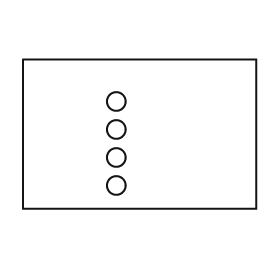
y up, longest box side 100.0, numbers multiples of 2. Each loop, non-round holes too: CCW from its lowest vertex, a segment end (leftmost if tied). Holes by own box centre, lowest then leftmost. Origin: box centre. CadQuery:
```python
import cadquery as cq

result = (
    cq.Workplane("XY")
    .moveTo(-50.0, -32.0)
    .lineTo(50.0, -32.0)
    .lineTo(50.0, 32.0)
    .lineTo(-50.0, 32.0)
    .close()
    .moveTo(-10.0, -22.0)
    .circle(4.0)
    .moveTo(-10.0, -10.0)
    .circle(4.0)
    .moveTo(-10.0, 2.0)
    .circle(4.0)
    .moveTo(-10.0, 14.0)
    .circle(4.0)
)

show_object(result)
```